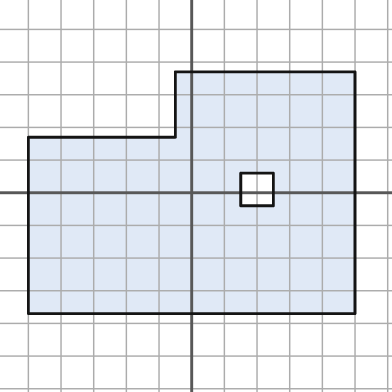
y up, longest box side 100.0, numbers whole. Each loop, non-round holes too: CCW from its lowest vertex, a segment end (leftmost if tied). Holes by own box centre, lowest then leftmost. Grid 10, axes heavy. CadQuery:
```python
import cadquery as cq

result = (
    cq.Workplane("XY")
    .moveTo(-50.0, -37.0)
    .lineTo(50.0, -37.0)
    .lineTo(50.0, 37.0)
    .lineTo(-5.0, 37.0)
    .lineTo(-5.0, 17.0)
    .lineTo(-50.0, 17.0)
    .close()
    .moveTo(15.0, -4.0)
    .lineTo(25.0, -4.0)
    .lineTo(25.0, 6.0)
    .lineTo(15.0, 6.0)
    .close()
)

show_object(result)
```